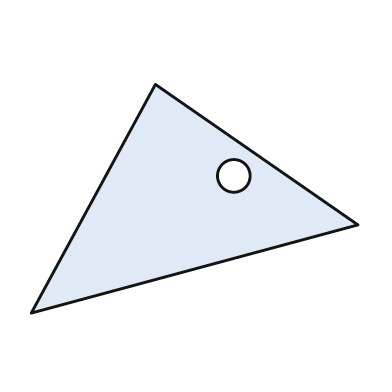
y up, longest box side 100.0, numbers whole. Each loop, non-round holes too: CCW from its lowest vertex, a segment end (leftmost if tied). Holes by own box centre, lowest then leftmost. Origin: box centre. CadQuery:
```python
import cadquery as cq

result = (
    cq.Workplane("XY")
    .moveTo(-50.0, -35.0)
    .lineTo(50.0, -8.0)
    .lineTo(-12.0, 35.0)
    .close()
    .moveTo(12.0, 7.0)
    .circle(5.0)
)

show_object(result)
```